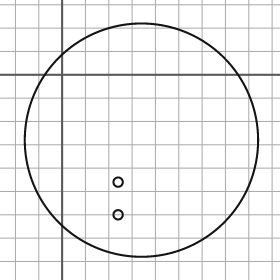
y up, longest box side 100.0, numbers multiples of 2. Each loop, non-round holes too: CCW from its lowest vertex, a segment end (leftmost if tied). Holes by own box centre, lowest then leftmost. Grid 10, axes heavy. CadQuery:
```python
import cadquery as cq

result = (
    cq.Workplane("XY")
    .moveTo(34.0, -28.0)
    .circle(50.0)
    .moveTo(24.0, -60.0)
    .circle(2.0)
    .moveTo(24.0, -46.0)
    .circle(2.0)
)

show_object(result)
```